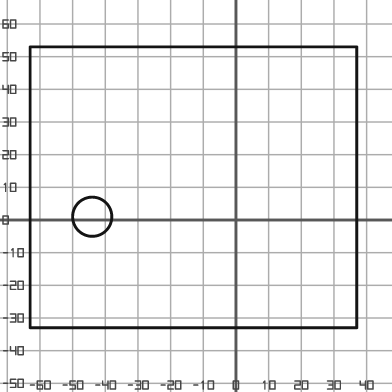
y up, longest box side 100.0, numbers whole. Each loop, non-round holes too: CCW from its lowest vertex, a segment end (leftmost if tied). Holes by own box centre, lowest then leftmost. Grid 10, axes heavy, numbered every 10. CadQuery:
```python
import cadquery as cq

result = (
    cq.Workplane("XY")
    .moveTo(-63.0, -33.0)
    .lineTo(37.0, -33.0)
    .lineTo(37.0, 53.0)
    .lineTo(-63.0, 53.0)
    .close()
    .moveTo(-44.0, 1.0)
    .circle(6.0)
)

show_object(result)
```